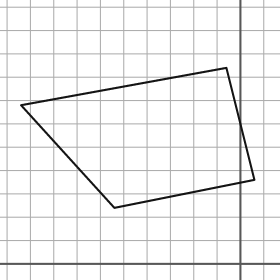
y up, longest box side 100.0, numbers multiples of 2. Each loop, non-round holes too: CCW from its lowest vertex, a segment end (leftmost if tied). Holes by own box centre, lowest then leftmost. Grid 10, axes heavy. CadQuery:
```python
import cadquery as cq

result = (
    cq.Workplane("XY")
    .moveTo(-54.0, 24.0)
    .lineTo(6.0, 36.0)
    .lineTo(-6.0, 84.0)
    .lineTo(-94.0, 68.0)
    .close()
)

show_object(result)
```